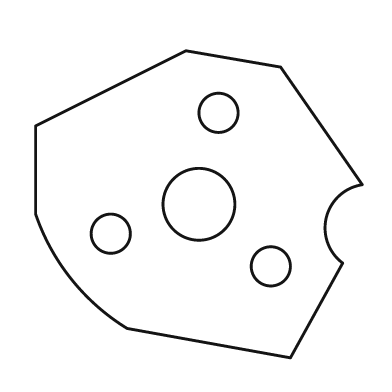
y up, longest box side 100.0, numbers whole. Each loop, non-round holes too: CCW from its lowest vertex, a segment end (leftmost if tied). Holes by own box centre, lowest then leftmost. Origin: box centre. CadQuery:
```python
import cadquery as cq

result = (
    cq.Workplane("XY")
    .moveTo(28.0, -47.0)
    .lineTo(44.0, -18.0)
    .threePointArc((39.0, -4.0), (50.0, 6.0))
    .lineTo(25.0, 42.0)
    .lineTo(-4.0, 47.0)
    .lineTo(-50.0, 24.0)
    .lineTo(-50.0, -3.0)
    .threePointArc((-39.0, -23.0), (-22.0, -38.0))
    .close()
    .moveTo(22.0, -19.0)
    .circle(6.0)
    .moveTo(-27.0, -9.0)
    .circle(6.0)
    .moveTo(0.0, 0.0)
    .circle(11.0)
    .moveTo(6.0, 28.0)
    .circle(6.0)
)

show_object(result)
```